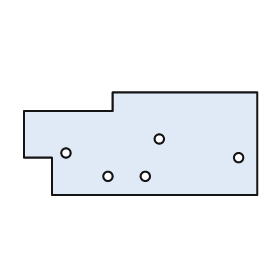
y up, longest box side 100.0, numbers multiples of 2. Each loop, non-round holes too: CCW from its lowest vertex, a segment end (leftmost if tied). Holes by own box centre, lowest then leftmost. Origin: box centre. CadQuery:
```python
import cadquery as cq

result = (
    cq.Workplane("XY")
    .moveTo(-38.0, -22.0)
    .lineTo(50.0, -22.0)
    .lineTo(50.0, 22.0)
    .lineTo(-12.0, 22.0)
    .lineTo(-12.0, 14.0)
    .lineTo(-50.0, 14.0)
    .lineTo(-50.0, -6.0)
    .lineTo(-38.0, -6.0)
    .close()
    .moveTo(-14.0, -14.0)
    .circle(2.0)
    .moveTo(2.0, -14.0)
    .circle(2.0)
    .moveTo(42.0, -6.0)
    .circle(2.0)
    .moveTo(-32.0, -4.0)
    .circle(2.0)
    .moveTo(8.0, 2.0)
    .circle(2.0)
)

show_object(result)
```